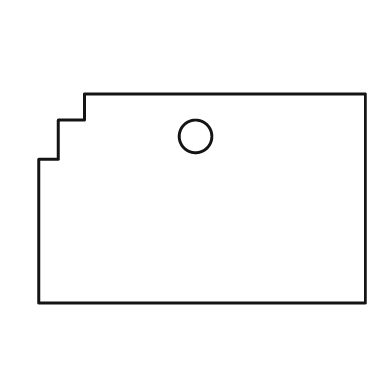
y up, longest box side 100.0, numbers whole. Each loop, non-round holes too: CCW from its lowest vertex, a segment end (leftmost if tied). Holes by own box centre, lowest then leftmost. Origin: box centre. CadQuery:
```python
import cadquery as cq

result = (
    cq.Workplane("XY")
    .moveTo(-50.0, -32.0)
    .lineTo(50.0, -32.0)
    .lineTo(50.0, 32.0)
    .lineTo(-36.0, 32.0)
    .lineTo(-36.0, 24.0)
    .lineTo(-44.0, 24.0)
    .lineTo(-44.0, 12.0)
    .lineTo(-50.0, 12.0)
    .close()
    .moveTo(-2.0, 19.0)
    .circle(5.0)
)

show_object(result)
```